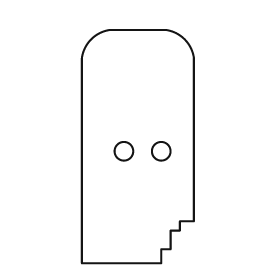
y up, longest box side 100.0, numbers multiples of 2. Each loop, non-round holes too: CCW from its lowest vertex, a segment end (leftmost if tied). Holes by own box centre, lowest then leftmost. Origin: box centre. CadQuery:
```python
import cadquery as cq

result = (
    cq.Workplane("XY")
    .moveTo(-24.0, -50.0)
    .lineTo(10.0, -50.0)
    .lineTo(10.0, -44.0)
    .lineTo(14.0, -44.0)
    .lineTo(14.0, -36.0)
    .lineTo(18.0, -36.0)
    .lineTo(18.0, -32.0)
    .lineTo(24.0, -32.0)
    .lineTo(24.0, 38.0)
    .threePointArc((20.0, 46.0), (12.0, 50.0))
    .lineTo(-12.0, 50.0)
    .threePointArc((-20.0, 46.0), (-24.0, 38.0))
    .close()
    .moveTo(-6.0, -2.0)
    .circle(4.0)
    .moveTo(10.0, -2.0)
    .circle(4.0)
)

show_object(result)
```